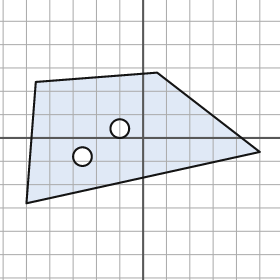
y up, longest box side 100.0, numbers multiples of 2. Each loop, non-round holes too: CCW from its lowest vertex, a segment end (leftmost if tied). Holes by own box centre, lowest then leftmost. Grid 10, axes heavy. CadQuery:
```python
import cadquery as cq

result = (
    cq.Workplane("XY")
    .moveTo(-50.0, -28.0)
    .lineTo(50.0, -6.0)
    .lineTo(6.0, 28.0)
    .lineTo(-46.0, 24.0)
    .close()
    .moveTo(-26.0, -8.0)
    .circle(4.0)
    .moveTo(-10.0, 4.0)
    .circle(4.0)
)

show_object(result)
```